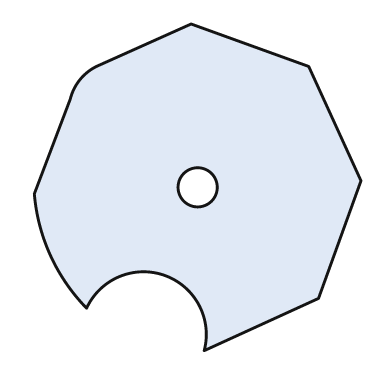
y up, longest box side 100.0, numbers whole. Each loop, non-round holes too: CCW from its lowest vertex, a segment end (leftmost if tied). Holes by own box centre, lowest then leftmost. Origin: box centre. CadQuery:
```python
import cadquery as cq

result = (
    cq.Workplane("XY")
    .moveTo(2.0, -50.0)
    .lineTo(37.0, -34.0)
    .lineTo(50.0, 2.0)
    .lineTo(34.0, 37.0)
    .lineTo(-2.0, 50.0)
    .lineTo(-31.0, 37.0)
    .threePointArc((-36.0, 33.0), (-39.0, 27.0))
    .lineTo(-50.0, -2.0)
    .threePointArc((-45.0, -21.0), (-34.0, -37.0))
    .threePointArc((-10.0, -27.0), (2.0, -50.0))
    .close()
    .moveTo(0.0, 0.0)
    .circle(6.0)
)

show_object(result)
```